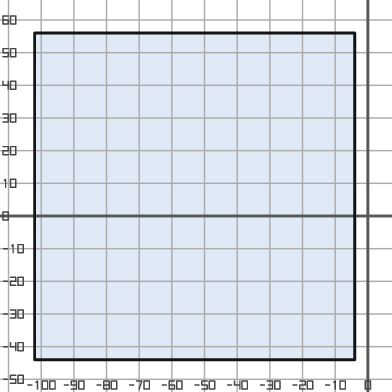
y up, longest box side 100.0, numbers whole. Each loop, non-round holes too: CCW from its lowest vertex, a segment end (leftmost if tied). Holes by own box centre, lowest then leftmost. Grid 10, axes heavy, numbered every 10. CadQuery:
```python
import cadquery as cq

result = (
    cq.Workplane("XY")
    .moveTo(-102.0, -44.0)
    .lineTo(-4.0, -44.0)
    .lineTo(-4.0, 56.0)
    .lineTo(-102.0, 56.0)
    .close()
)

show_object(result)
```